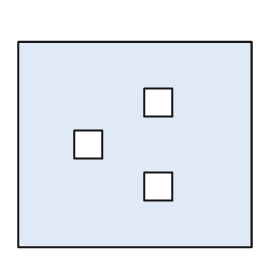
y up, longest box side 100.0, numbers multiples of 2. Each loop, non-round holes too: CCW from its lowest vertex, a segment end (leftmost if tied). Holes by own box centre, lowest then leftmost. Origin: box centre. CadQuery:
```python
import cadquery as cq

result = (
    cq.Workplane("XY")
    .moveTo(-50.0, -44.0)
    .lineTo(50.0, -44.0)
    .lineTo(50.0, 44.0)
    .lineTo(-50.0, 44.0)
    .close()
    .moveTo(4.0, -24.0)
    .lineTo(16.0, -24.0)
    .lineTo(16.0, -12.0)
    .lineTo(4.0, -12.0)
    .close()
    .moveTo(-26.0, -6.0)
    .lineTo(-14.0, -6.0)
    .lineTo(-14.0, 6.0)
    .lineTo(-26.0, 6.0)
    .close()
    .moveTo(4.0, 12.0)
    .lineTo(16.0, 12.0)
    .lineTo(16.0, 24.0)
    .lineTo(4.0, 24.0)
    .close()
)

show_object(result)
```